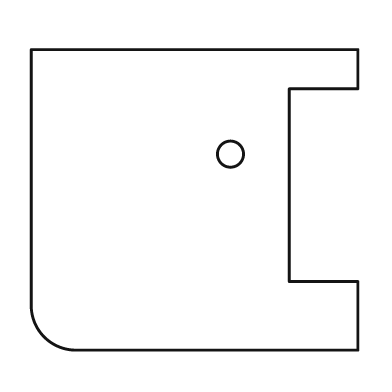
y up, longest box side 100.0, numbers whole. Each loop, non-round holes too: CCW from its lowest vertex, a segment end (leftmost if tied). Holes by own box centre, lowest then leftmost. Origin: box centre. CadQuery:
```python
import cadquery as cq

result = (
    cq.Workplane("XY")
    .moveTo(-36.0, -46.0)
    .lineTo(50.0, -46.0)
    .lineTo(50.0, -25.0)
    .lineTo(29.0, -25.0)
    .lineTo(29.0, 34.0)
    .lineTo(50.0, 34.0)
    .lineTo(50.0, 46.0)
    .lineTo(-50.0, 46.0)
    .lineTo(-50.0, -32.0)
    .threePointArc((-46.0, -42.0), (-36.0, -46.0))
    .close()
    .moveTo(11.0, 14.0)
    .circle(4.0)
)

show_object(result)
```